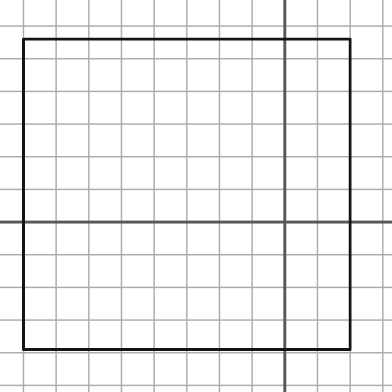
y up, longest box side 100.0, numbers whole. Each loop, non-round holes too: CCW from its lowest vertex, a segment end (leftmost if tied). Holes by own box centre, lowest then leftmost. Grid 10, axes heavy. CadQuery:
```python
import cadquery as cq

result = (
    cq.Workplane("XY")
    .moveTo(-80.0, -39.0)
    .lineTo(20.0, -39.0)
    .lineTo(20.0, 56.0)
    .lineTo(-80.0, 56.0)
    .close()
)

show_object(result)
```